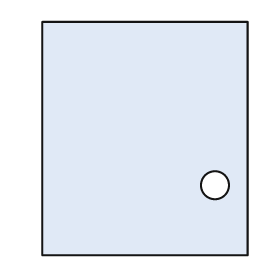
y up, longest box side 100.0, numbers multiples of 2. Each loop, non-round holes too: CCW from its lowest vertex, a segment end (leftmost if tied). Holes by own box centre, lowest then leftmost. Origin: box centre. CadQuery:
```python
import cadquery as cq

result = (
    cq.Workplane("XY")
    .moveTo(-44.0, -50.0)
    .lineTo(44.0, -50.0)
    .lineTo(44.0, 50.0)
    .lineTo(-44.0, 50.0)
    .close()
    .moveTo(30.0, -20.0)
    .circle(6.0)
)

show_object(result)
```